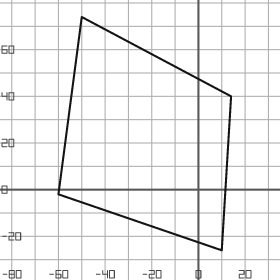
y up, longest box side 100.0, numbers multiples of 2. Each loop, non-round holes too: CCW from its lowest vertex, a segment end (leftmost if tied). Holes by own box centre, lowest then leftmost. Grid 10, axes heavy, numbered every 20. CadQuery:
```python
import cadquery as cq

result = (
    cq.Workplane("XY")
    .moveTo(10.0, -26.0)
    .lineTo(14.0, 40.0)
    .lineTo(-50.0, 74.0)
    .lineTo(-60.0, -2.0)
    .close()
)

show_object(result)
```